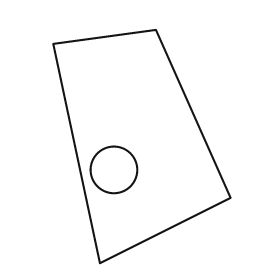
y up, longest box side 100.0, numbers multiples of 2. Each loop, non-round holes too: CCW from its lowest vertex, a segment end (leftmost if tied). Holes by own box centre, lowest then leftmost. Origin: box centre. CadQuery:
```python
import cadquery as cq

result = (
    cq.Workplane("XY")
    .moveTo(-18.0, -50.0)
    .lineTo(38.0, -22.0)
    .lineTo(6.0, 50.0)
    .lineTo(-38.0, 44.0)
    .close()
    .moveTo(-12.0, -10.0)
    .circle(10.0)
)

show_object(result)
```